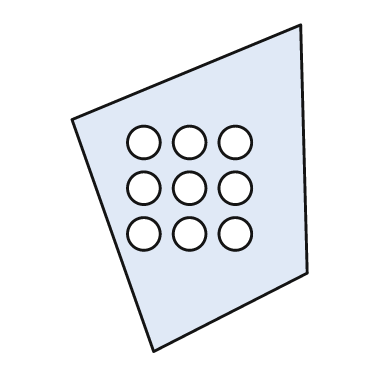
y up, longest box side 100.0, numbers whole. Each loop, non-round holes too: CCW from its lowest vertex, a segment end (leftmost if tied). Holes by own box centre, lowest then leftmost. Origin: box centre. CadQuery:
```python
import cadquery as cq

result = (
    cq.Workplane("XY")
    .moveTo(-11.0, -50.0)
    .lineTo(36.0, -26.0)
    .lineTo(34.0, 50.0)
    .lineTo(-36.0, 21.0)
    .close()
    .moveTo(-14.0, -14.0)
    .circle(5.0)
    .moveTo(0.0, -14.0)
    .circle(5.0)
    .moveTo(14.0, -14.0)
    .circle(5.0)
    .moveTo(-14.0, 0.0)
    .circle(5.0)
    .moveTo(0.0, 0.0)
    .circle(5.0)
    .moveTo(14.0, 0.0)
    .circle(5.0)
    .moveTo(-14.0, 14.0)
    .circle(5.0)
    .moveTo(0.0, 14.0)
    .circle(5.0)
    .moveTo(14.0, 14.0)
    .circle(5.0)
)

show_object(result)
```